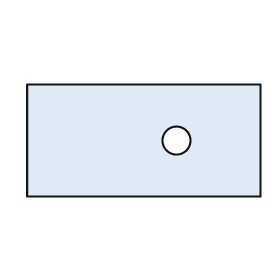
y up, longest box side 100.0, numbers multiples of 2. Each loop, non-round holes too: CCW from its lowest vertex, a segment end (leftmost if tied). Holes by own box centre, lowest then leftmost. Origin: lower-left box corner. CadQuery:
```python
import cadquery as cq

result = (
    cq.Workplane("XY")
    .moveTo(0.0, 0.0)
    .lineTo(100.0, 0.0)
    .lineTo(100.0, 48.0)
    .lineTo(0.0, 48.0)
    .close()
    .moveTo(64.0, 24.0)
    .circle(6.0)
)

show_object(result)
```